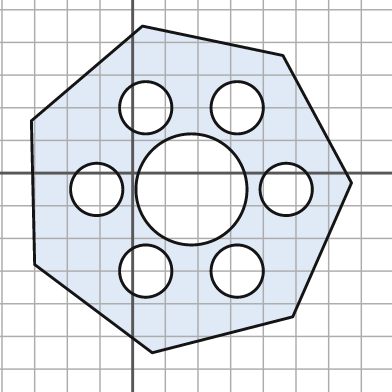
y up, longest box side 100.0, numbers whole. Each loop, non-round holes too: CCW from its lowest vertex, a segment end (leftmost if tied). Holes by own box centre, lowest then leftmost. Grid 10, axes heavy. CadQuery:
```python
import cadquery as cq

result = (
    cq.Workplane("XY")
    .moveTo(6.0, -55.0)
    .lineTo(49.0, -44.0)
    .lineTo(67.0, -3.0)
    .lineTo(46.0, 36.0)
    .lineTo(3.0, 45.0)
    .lineTo(-31.0, 16.0)
    .lineTo(-30.0, -28.0)
    .close()
    .moveTo(4.0, -30.0)
    .circle(8.0)
    .moveTo(32.0, -30.0)
    .circle(8.0)
    .moveTo(-11.0, -5.0)
    .circle(8.0)
    .moveTo(18.0, -5.0)
    .circle(17.0)
    .moveTo(47.0, -5.0)
    .circle(8.0)
    .moveTo(4.0, 20.0)
    .circle(8.0)
    .moveTo(32.0, 20.0)
    .circle(8.0)
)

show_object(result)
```